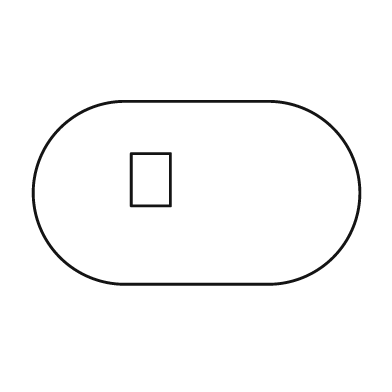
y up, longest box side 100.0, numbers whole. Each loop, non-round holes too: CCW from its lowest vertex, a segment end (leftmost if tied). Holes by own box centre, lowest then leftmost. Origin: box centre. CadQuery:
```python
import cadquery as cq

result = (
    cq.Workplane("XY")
    .moveTo(-22.0, -28.0)
    .lineTo(22.0, -28.0)
    .threePointArc((50.0, 0.0), (22.0, 28.0))
    .lineTo(-22.0, 28.0)
    .threePointArc((-50.0, 0.0), (-22.0, -28.0))
    .close()
    .moveTo(-20.0, -4.0)
    .lineTo(-8.0, -4.0)
    .lineTo(-8.0, 12.0)
    .lineTo(-20.0, 12.0)
    .close()
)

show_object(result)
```